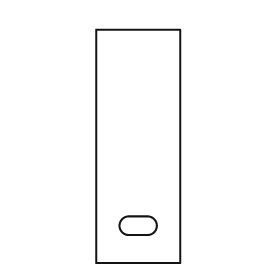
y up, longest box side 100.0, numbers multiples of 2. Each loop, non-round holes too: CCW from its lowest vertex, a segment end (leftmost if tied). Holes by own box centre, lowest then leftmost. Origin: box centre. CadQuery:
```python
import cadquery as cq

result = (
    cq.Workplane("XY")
    .moveTo(-18.0, -50.0)
    .lineTo(18.0, -50.0)
    .lineTo(18.0, 50.0)
    .lineTo(-18.0, 50.0)
    .close()
    .moveTo(-4.0, -38.0)
    .lineTo(4.0, -38.0)
    .threePointArc((8.0, -34.0), (4.0, -30.0))
    .lineTo(-4.0, -30.0)
    .threePointArc((-8.0, -34.0), (-4.0, -38.0))
    .close()
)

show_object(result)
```